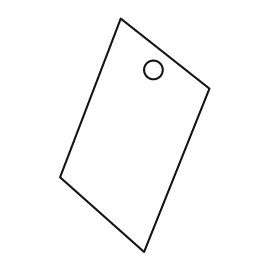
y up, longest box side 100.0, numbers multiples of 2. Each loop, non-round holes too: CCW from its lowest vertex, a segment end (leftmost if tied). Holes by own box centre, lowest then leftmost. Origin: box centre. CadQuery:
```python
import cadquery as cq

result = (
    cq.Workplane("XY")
    .moveTo(4.0, -50.0)
    .lineTo(32.0, 20.0)
    .lineTo(-6.0, 50.0)
    .lineTo(-32.0, -18.0)
    .close()
    .moveTo(8.0, 28.0)
    .circle(4.0)
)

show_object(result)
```